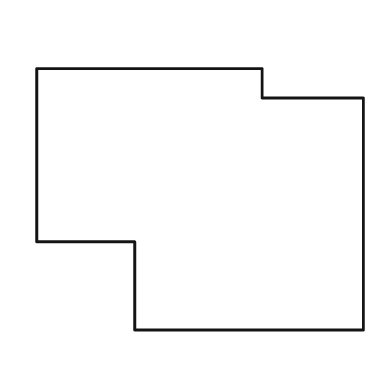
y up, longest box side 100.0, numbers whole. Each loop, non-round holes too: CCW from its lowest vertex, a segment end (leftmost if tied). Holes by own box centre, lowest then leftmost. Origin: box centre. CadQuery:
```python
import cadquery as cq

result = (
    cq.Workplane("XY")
    .moveTo(-20.0, -40.0)
    .lineTo(50.0, -40.0)
    .lineTo(50.0, 31.0)
    .lineTo(19.0, 31.0)
    .lineTo(19.0, 40.0)
    .lineTo(-50.0, 40.0)
    .lineTo(-50.0, -13.0)
    .lineTo(-20.0, -13.0)
    .close()
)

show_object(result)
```